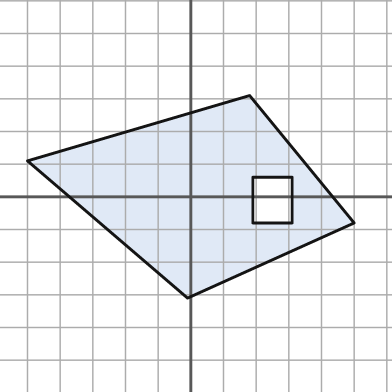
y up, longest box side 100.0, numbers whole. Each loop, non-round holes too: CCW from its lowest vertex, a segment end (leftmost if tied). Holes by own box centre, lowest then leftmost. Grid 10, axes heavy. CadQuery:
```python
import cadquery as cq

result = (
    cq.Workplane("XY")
    .moveTo(-1.0, -31.0)
    .lineTo(50.0, -8.0)
    .lineTo(18.0, 31.0)
    .lineTo(-50.0, 11.0)
    .close()
    .moveTo(19.0, -8.0)
    .lineTo(31.0, -8.0)
    .lineTo(31.0, 6.0)
    .lineTo(19.0, 6.0)
    .close()
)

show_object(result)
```